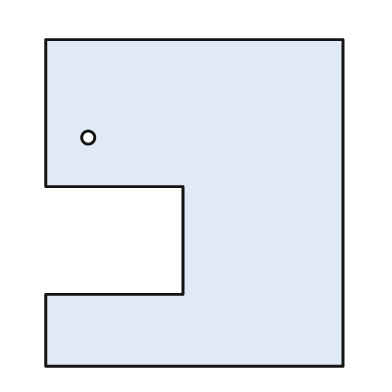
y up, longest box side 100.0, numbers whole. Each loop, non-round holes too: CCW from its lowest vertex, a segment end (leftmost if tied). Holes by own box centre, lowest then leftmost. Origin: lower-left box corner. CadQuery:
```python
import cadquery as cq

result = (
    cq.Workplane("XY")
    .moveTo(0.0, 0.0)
    .lineTo(91.0, 0.0)
    .lineTo(91.0, 100.0)
    .lineTo(0.0, 100.0)
    .lineTo(0.0, 55.0)
    .lineTo(42.0, 55.0)
    .lineTo(42.0, 22.0)
    .lineTo(0.0, 22.0)
    .close()
    .moveTo(13.0, 70.0)
    .circle(2.0)
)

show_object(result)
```